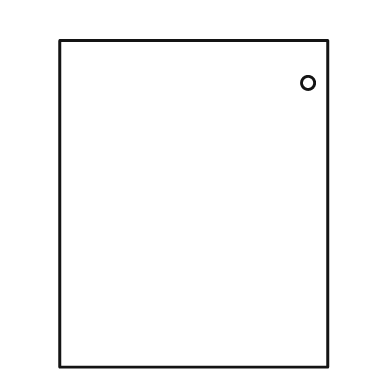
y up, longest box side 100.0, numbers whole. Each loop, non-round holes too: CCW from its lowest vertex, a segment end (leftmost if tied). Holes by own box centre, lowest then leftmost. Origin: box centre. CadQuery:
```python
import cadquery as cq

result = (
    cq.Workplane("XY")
    .moveTo(-41.0, -50.0)
    .lineTo(41.0, -50.0)
    .lineTo(41.0, 50.0)
    .lineTo(-41.0, 50.0)
    .close()
    .moveTo(35.0, 37.0)
    .circle(2.0)
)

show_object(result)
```